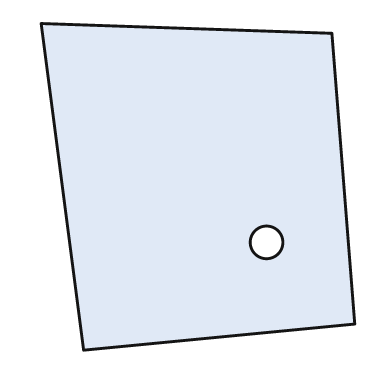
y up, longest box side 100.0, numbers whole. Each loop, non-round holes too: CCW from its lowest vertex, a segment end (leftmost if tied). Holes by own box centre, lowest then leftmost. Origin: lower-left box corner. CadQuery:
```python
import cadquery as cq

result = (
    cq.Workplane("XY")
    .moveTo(13.0, 0.0)
    .lineTo(96.0, 8.0)
    .lineTo(89.0, 97.0)
    .lineTo(0.0, 100.0)
    .close()
    .moveTo(69.0, 33.0)
    .circle(5.0)
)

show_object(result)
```